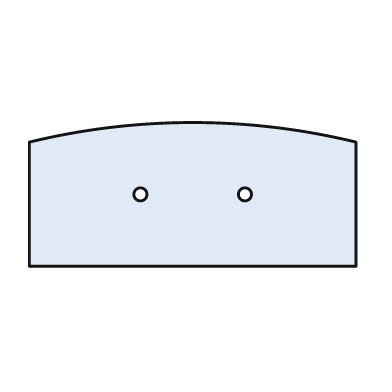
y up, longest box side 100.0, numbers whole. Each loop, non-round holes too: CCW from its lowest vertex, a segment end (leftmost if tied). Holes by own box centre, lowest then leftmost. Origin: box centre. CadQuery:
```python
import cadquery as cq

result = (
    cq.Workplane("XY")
    .moveTo(-50.0, -22.0)
    .lineTo(50.0, -22.0)
    .lineTo(50.0, 16.0)
    .threePointArc((0.0, 22.0), (-50.0, 16.0))
    .close()
    .moveTo(-16.0, 0.0)
    .circle(2.0)
    .moveTo(16.0, 0.0)
    .circle(2.0)
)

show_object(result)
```